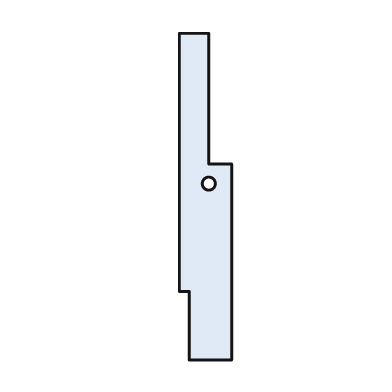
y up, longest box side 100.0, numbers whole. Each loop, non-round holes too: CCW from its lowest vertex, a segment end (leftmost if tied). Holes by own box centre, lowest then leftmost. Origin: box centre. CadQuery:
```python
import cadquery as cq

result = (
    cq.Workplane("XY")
    .moveTo(-5.0, -50.0)
    .lineTo(8.0, -50.0)
    .lineTo(8.0, 10.0)
    .lineTo(1.0, 10.0)
    .lineTo(1.0, 50.0)
    .lineTo(-8.0, 50.0)
    .lineTo(-8.0, -29.0)
    .lineTo(-5.0, -29.0)
    .close()
    .moveTo(1.0, 4.0)
    .circle(2.0)
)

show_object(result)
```